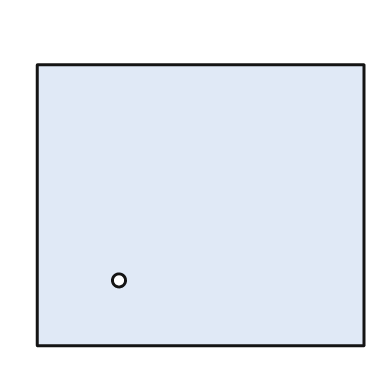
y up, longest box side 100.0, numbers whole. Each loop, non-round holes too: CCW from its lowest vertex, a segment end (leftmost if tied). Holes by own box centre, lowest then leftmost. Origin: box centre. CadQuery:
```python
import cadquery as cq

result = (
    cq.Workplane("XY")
    .moveTo(-50.0, -43.0)
    .lineTo(50.0, -43.0)
    .lineTo(50.0, 43.0)
    .lineTo(-50.0, 43.0)
    .close()
    .moveTo(-25.0, -23.0)
    .circle(2.0)
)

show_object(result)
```